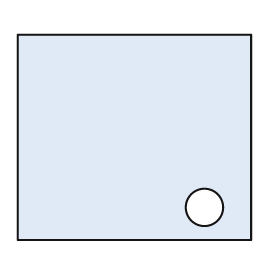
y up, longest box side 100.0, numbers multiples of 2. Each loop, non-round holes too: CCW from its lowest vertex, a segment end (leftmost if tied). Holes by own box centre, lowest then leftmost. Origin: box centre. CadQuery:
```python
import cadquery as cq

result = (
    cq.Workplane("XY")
    .moveTo(-50.0, -44.0)
    .lineTo(50.0, -44.0)
    .lineTo(50.0, 44.0)
    .lineTo(-50.0, 44.0)
    .close()
    .moveTo(30.0, -30.0)
    .circle(8.0)
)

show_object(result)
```